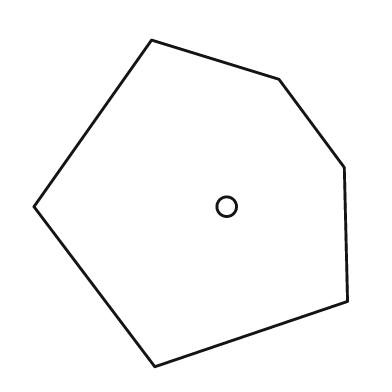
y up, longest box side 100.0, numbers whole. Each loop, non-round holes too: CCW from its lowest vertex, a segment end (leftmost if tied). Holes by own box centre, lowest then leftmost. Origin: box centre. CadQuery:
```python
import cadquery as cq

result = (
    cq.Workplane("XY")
    .moveTo(-11.0, -50.0)
    .lineTo(48.0, -30.0)
    .lineTo(47.0, 11.0)
    .lineTo(27.0, 38.0)
    .lineTo(-12.0, 50.0)
    .lineTo(-48.0, -1.0)
    .close()
    .moveTo(11.0, -1.0)
    .circle(3.0)
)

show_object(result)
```